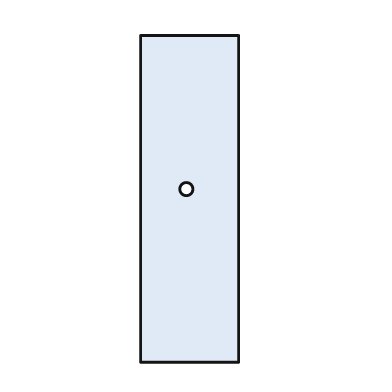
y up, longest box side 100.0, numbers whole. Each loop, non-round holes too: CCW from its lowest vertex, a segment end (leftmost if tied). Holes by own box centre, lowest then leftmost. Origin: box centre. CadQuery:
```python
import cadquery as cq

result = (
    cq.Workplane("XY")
    .moveTo(-15.0, -50.0)
    .lineTo(15.0, -50.0)
    .lineTo(15.0, 50.0)
    .lineTo(-15.0, 50.0)
    .close()
    .moveTo(-1.0, 3.0)
    .circle(2.0)
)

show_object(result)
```